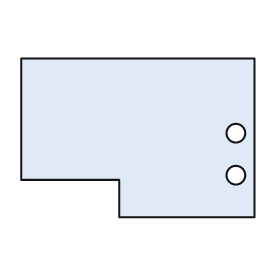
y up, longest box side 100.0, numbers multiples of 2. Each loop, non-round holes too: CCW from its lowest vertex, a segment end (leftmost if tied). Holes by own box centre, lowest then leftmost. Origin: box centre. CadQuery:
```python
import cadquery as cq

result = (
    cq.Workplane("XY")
    .moveTo(-8.0, -34.0)
    .lineTo(50.0, -34.0)
    .lineTo(50.0, 34.0)
    .lineTo(-50.0, 34.0)
    .lineTo(-50.0, -18.0)
    .lineTo(-8.0, -18.0)
    .close()
    .moveTo(42.0, -16.0)
    .circle(4.0)
    .moveTo(42.0, 2.0)
    .circle(4.0)
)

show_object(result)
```